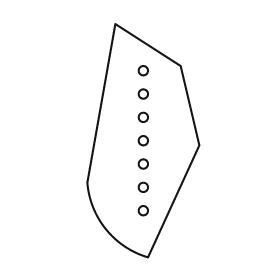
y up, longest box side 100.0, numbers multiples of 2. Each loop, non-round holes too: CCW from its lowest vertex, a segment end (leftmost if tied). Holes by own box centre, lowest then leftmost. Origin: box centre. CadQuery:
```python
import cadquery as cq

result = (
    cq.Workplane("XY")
    .moveTo(2.0, -50.0)
    .lineTo(24.0, -2.0)
    .lineTo(16.0, 32.0)
    .lineTo(-12.0, 50.0)
    .lineTo(-24.0, -18.0)
    .threePointArc((-16.0, -38.0), (2.0, -50.0))
    .close()
    .moveTo(0.0, -30.0)
    .circle(2.0)
    .moveTo(0.0, -20.0)
    .circle(2.0)
    .moveTo(0.0, -10.0)
    .circle(2.0)
    .moveTo(0.0, 0.0)
    .circle(2.0)
    .moveTo(0.0, 10.0)
    .circle(2.0)
    .moveTo(0.0, 20.0)
    .circle(2.0)
    .moveTo(0.0, 30.0)
    .circle(2.0)
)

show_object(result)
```